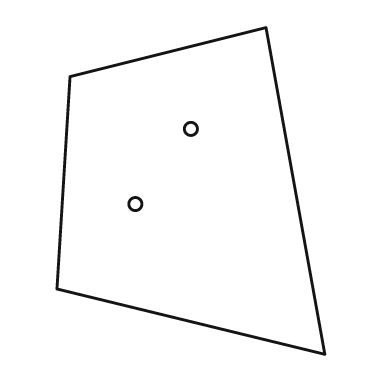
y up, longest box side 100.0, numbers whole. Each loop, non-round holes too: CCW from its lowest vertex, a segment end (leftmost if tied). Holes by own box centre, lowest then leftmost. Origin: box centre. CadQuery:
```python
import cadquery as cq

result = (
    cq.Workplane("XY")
    .moveTo(41.0, -50.0)
    .lineTo(23.0, 50.0)
    .lineTo(-37.0, 35.0)
    .lineTo(-41.0, -30.0)
    .close()
    .moveTo(-17.0, -4.0)
    .circle(2.0)
    .moveTo(0.0, 19.0)
    .circle(2.0)
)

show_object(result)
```